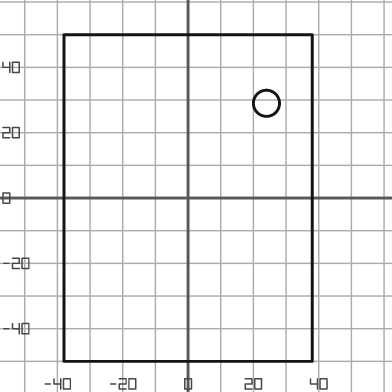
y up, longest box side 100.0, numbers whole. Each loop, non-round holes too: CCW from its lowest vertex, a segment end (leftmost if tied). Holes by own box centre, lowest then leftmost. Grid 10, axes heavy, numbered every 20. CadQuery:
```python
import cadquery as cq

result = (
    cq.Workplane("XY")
    .moveTo(-38.0, -50.0)
    .lineTo(38.0, -50.0)
    .lineTo(38.0, 50.0)
    .lineTo(-38.0, 50.0)
    .close()
    .moveTo(24.0, 29.0)
    .circle(4.0)
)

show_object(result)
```